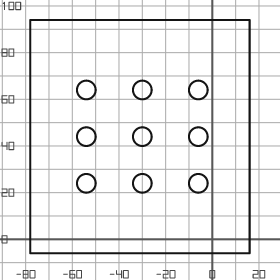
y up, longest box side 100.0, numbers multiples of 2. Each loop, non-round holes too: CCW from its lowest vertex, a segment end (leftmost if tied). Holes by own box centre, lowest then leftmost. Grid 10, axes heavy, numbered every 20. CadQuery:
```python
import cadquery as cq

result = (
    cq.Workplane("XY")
    .moveTo(-78.0, -6.0)
    .lineTo(16.0, -6.0)
    .lineTo(16.0, 94.0)
    .lineTo(-78.0, 94.0)
    .close()
    .moveTo(-54.0, 24.0)
    .circle(4.0)
    .moveTo(-30.0, 24.0)
    .circle(4.0)
    .moveTo(-6.0, 24.0)
    .circle(4.0)
    .moveTo(-54.0, 44.0)
    .circle(4.0)
    .moveTo(-30.0, 44.0)
    .circle(4.0)
    .moveTo(-6.0, 44.0)
    .circle(4.0)
    .moveTo(-54.0, 64.0)
    .circle(4.0)
    .moveTo(-30.0, 64.0)
    .circle(4.0)
    .moveTo(-6.0, 64.0)
    .circle(4.0)
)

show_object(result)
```